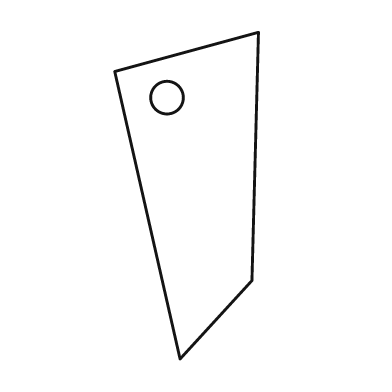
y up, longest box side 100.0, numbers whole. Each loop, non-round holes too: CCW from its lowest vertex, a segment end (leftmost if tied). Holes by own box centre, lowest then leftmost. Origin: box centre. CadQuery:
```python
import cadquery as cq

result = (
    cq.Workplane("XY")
    .moveTo(-2.0, -50.0)
    .lineTo(20.0, -26.0)
    .lineTo(22.0, 50.0)
    .lineTo(-22.0, 38.0)
    .close()
    .moveTo(-6.0, 30.0)
    .circle(5.0)
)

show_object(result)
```